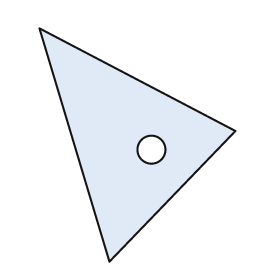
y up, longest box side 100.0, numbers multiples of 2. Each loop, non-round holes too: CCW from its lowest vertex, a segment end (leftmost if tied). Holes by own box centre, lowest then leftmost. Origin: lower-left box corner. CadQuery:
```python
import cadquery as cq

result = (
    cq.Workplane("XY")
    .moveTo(30.0, 0.0)
    .lineTo(84.0, 56.0)
    .lineTo(0.0, 100.0)
    .close()
    .moveTo(48.0, 48.0)
    .circle(6.0)
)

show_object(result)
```